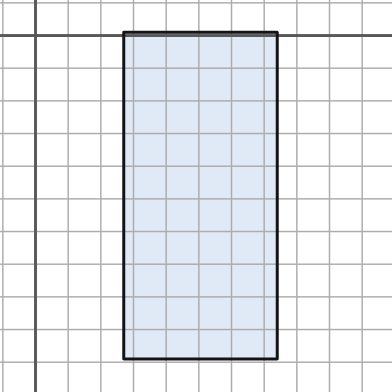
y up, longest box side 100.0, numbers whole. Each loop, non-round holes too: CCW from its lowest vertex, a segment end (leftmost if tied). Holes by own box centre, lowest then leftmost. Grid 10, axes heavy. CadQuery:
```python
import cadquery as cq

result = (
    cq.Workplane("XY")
    .moveTo(27.0, -99.0)
    .lineTo(74.0, -99.0)
    .lineTo(74.0, 1.0)
    .lineTo(27.0, 1.0)
    .close()
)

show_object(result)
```